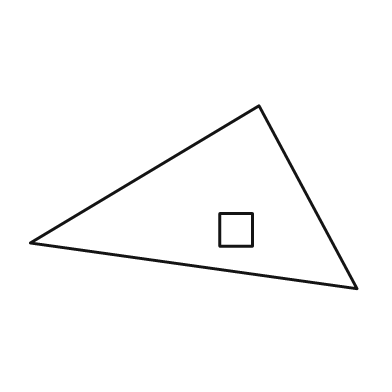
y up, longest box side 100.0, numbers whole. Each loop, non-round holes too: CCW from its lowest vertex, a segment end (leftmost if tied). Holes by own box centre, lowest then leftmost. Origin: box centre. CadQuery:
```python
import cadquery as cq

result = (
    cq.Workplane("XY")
    .moveTo(50.0, -28.0)
    .lineTo(20.0, 28.0)
    .lineTo(-50.0, -14.0)
    .close()
    .moveTo(8.0, -15.0)
    .lineTo(18.0, -15.0)
    .lineTo(18.0, -5.0)
    .lineTo(8.0, -5.0)
    .close()
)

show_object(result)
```